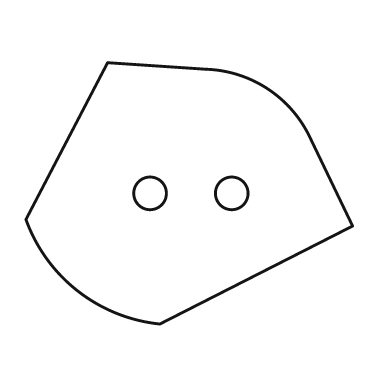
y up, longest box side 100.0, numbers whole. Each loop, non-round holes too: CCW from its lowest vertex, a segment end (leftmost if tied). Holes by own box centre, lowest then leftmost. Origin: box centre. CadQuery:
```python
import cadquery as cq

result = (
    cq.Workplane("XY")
    .moveTo(-9.0, -40.0)
    .lineTo(50.0, -10.0)
    .lineTo(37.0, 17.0)
    .threePointArc((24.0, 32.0), (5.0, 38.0))
    .lineTo(-25.0, 40.0)
    .lineTo(-50.0, -8.0)
    .threePointArc((-34.0, -30.0), (-9.0, -40.0))
    .close()
    .moveTo(-12.0, 0.0)
    .circle(5.0)
    .moveTo(13.0, 0.0)
    .circle(5.0)
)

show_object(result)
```